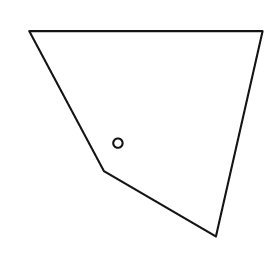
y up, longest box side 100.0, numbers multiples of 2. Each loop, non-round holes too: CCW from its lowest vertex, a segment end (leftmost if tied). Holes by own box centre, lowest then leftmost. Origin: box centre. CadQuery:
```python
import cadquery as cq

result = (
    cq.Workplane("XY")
    .moveTo(30.0, -44.0)
    .lineTo(50.0, 44.0)
    .lineTo(-50.0, 44.0)
    .lineTo(-18.0, -16.0)
    .close()
    .moveTo(-12.0, -4.0)
    .circle(2.0)
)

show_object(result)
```